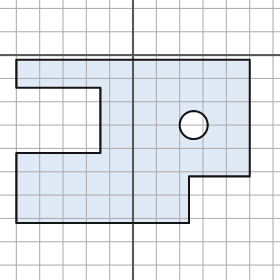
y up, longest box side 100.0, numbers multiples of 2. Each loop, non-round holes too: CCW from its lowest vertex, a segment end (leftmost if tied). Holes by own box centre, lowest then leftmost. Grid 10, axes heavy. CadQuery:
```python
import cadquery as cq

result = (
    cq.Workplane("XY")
    .moveTo(-50.0, -72.0)
    .lineTo(24.0, -72.0)
    .lineTo(24.0, -52.0)
    .lineTo(50.0, -52.0)
    .lineTo(50.0, -2.0)
    .lineTo(-50.0, -2.0)
    .lineTo(-50.0, -14.0)
    .lineTo(-14.0, -14.0)
    .lineTo(-14.0, -42.0)
    .lineTo(-50.0, -42.0)
    .close()
    .moveTo(26.0, -30.0)
    .circle(6.0)
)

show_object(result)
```